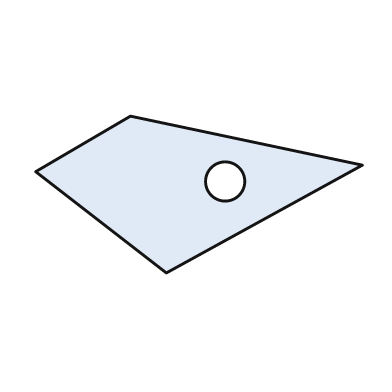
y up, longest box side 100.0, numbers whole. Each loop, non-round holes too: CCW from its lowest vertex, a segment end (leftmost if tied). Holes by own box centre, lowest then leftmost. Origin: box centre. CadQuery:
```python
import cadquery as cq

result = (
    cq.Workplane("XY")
    .moveTo(-10.0, -24.0)
    .lineTo(50.0, 9.0)
    .lineTo(-21.0, 24.0)
    .lineTo(-50.0, 7.0)
    .close()
    .moveTo(8.0, 4.0)
    .circle(6.0)
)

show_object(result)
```